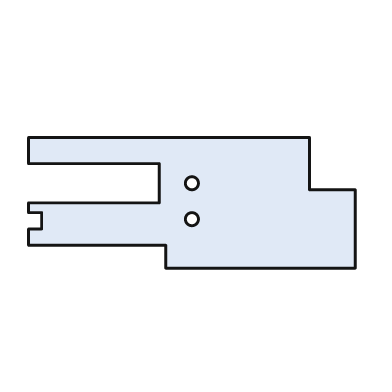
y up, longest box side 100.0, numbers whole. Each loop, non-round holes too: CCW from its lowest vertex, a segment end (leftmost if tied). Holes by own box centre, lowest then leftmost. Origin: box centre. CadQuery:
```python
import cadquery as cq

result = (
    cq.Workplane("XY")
    .moveTo(-8.0, -20.0)
    .lineTo(50.0, -20.0)
    .lineTo(50.0, 4.0)
    .lineTo(36.0, 4.0)
    .lineTo(36.0, 20.0)
    .lineTo(-50.0, 20.0)
    .lineTo(-50.0, 12.0)
    .lineTo(-10.0, 12.0)
    .lineTo(-10.0, 0.0)
    .lineTo(-50.0, 0.0)
    .lineTo(-50.0, -3.0)
    .lineTo(-46.0, -3.0)
    .lineTo(-46.0, -8.0)
    .lineTo(-50.0, -8.0)
    .lineTo(-50.0, -13.0)
    .lineTo(-8.0, -13.0)
    .close()
    .moveTo(0.0, -5.0)
    .circle(2.0)
    .moveTo(0.0, 6.0)
    .circle(2.0)
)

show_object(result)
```